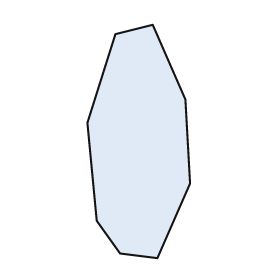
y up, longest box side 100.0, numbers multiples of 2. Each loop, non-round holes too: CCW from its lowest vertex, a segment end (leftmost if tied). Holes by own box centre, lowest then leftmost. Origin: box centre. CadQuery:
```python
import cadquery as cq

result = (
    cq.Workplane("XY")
    .moveTo(8.0, -50.0)
    .lineTo(22.0, -18.0)
    .lineTo(20.0, 18.0)
    .lineTo(6.0, 50.0)
    .lineTo(-10.0, 46.0)
    .lineTo(-22.0, 8.0)
    .lineTo(-18.0, -34.0)
    .lineTo(-8.0, -48.0)
    .close()
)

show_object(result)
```